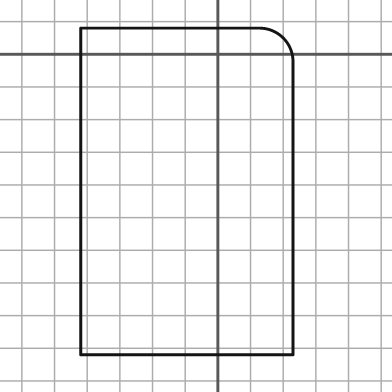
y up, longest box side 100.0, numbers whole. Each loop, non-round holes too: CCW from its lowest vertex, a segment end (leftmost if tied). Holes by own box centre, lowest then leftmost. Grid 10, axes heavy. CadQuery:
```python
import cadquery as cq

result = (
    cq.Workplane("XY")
    .moveTo(-42.0, -92.0)
    .lineTo(23.0, -92.0)
    .lineTo(23.0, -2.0)
    .threePointArc((20.0, 5.0), (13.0, 8.0))
    .lineTo(-42.0, 8.0)
    .close()
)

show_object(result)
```